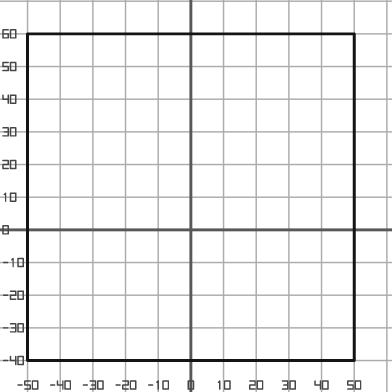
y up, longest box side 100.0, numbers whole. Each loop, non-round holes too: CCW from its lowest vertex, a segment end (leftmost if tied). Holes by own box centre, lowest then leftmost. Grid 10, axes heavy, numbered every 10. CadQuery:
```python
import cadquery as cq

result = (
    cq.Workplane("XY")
    .moveTo(-50.0, -40.0)
    .lineTo(50.0, -40.0)
    .lineTo(50.0, 60.0)
    .lineTo(-50.0, 60.0)
    .close()
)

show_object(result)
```